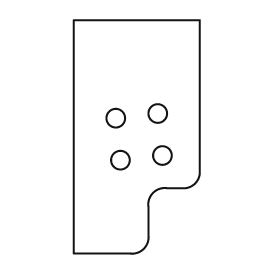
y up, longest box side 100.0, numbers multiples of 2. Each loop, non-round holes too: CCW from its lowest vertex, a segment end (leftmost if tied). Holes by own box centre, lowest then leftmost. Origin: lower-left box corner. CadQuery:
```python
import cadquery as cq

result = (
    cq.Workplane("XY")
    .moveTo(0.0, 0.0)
    .lineTo(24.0, 0.0)
    .threePointArc((30.0, 2.0), (32.0, 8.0))
    .lineTo(32.0, 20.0)
    .threePointArc((34.0, 26.0), (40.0, 28.0))
    .lineTo(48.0, 28.0)
    .threePointArc((52.0, 30.0), (54.0, 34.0))
    .lineTo(54.0, 100.0)
    .lineTo(0.0, 100.0)
    .close()
    .moveTo(20.0, 40.0)
    .circle(4.0)
    .moveTo(38.0, 42.0)
    .circle(4.0)
    .moveTo(18.0, 58.0)
    .circle(4.0)
    .moveTo(36.0, 60.0)
    .circle(4.0)
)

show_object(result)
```